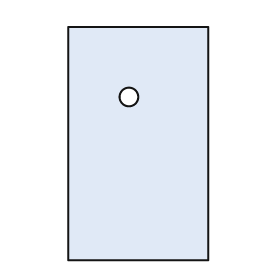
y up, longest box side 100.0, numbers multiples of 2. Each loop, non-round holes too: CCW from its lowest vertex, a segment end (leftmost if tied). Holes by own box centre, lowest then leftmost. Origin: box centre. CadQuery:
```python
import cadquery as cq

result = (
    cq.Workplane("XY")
    .moveTo(-30.0, -50.0)
    .lineTo(30.0, -50.0)
    .lineTo(30.0, 50.0)
    .lineTo(-30.0, 50.0)
    .close()
    .moveTo(-4.0, 20.0)
    .circle(4.0)
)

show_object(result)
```